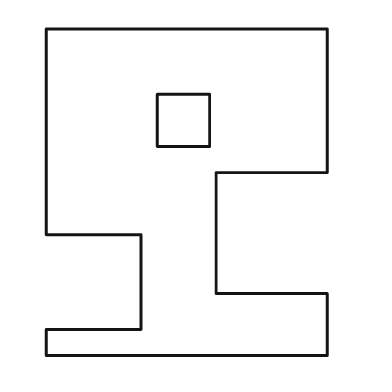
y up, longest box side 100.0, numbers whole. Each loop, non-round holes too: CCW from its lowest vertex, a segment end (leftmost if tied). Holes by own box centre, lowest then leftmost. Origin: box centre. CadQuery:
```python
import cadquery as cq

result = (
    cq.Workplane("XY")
    .moveTo(-43.0, -50.0)
    .lineTo(43.0, -50.0)
    .lineTo(43.0, -31.0)
    .lineTo(9.0, -31.0)
    .lineTo(9.0, 6.0)
    .lineTo(43.0, 6.0)
    .lineTo(43.0, 50.0)
    .lineTo(-43.0, 50.0)
    .lineTo(-43.0, -13.0)
    .lineTo(-14.0, -13.0)
    .lineTo(-14.0, -42.0)
    .lineTo(-43.0, -42.0)
    .close()
    .moveTo(-9.0, 14.0)
    .lineTo(7.0, 14.0)
    .lineTo(7.0, 30.0)
    .lineTo(-9.0, 30.0)
    .close()
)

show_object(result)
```